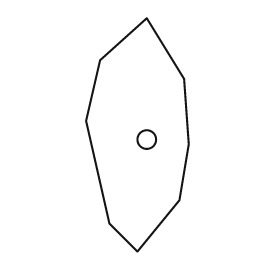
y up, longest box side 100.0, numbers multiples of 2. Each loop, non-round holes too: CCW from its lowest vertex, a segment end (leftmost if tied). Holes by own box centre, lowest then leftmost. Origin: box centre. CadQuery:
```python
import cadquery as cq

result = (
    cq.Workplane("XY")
    .moveTo(0.0, -50.0)
    .lineTo(18.0, -28.0)
    .lineTo(22.0, -4.0)
    .lineTo(20.0, 24.0)
    .lineTo(4.0, 50.0)
    .lineTo(-16.0, 32.0)
    .lineTo(-22.0, 6.0)
    .lineTo(-12.0, -38.0)
    .close()
    .moveTo(4.0, -2.0)
    .circle(4.0)
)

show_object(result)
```